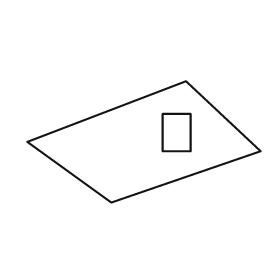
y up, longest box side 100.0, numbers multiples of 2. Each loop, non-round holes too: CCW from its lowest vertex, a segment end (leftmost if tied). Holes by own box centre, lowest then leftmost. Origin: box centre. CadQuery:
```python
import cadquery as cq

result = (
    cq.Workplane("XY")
    .moveTo(-14.0, -26.0)
    .lineTo(50.0, -4.0)
    .lineTo(18.0, 26.0)
    .lineTo(-50.0, 0.0)
    .close()
    .moveTo(8.0, -4.0)
    .lineTo(20.0, -4.0)
    .lineTo(20.0, 12.0)
    .lineTo(8.0, 12.0)
    .close()
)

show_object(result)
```